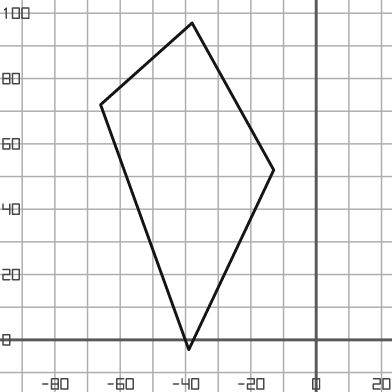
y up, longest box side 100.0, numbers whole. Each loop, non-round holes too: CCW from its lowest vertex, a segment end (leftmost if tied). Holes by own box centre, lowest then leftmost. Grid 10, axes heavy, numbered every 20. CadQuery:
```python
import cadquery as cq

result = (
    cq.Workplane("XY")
    .moveTo(-39.0, -3.0)
    .lineTo(-13.0, 52.0)
    .lineTo(-38.0, 97.0)
    .lineTo(-66.0, 72.0)
    .close()
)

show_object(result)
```